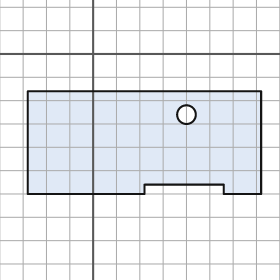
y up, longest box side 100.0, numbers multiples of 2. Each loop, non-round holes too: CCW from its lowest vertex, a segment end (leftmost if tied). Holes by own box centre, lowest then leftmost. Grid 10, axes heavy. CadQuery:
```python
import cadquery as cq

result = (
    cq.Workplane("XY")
    .moveTo(-28.0, -60.0)
    .lineTo(22.0, -60.0)
    .lineTo(22.0, -56.0)
    .lineTo(56.0, -56.0)
    .lineTo(56.0, -60.0)
    .lineTo(72.0, -60.0)
    .lineTo(72.0, -16.0)
    .lineTo(-28.0, -16.0)
    .close()
    .moveTo(40.0, -26.0)
    .circle(4.0)
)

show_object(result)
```